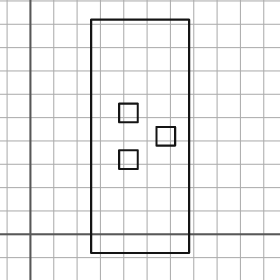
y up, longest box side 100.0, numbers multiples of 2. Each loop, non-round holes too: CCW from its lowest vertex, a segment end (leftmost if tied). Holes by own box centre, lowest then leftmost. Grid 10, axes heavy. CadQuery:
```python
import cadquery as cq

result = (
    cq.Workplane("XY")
    .moveTo(26.0, -8.0)
    .lineTo(68.0, -8.0)
    .lineTo(68.0, 92.0)
    .lineTo(26.0, 92.0)
    .close()
    .moveTo(38.0, 28.0)
    .lineTo(46.0, 28.0)
    .lineTo(46.0, 36.0)
    .lineTo(38.0, 36.0)
    .close()
    .moveTo(54.0, 38.0)
    .lineTo(62.0, 38.0)
    .lineTo(62.0, 46.0)
    .lineTo(54.0, 46.0)
    .close()
    .moveTo(38.0, 48.0)
    .lineTo(46.0, 48.0)
    .lineTo(46.0, 56.0)
    .lineTo(38.0, 56.0)
    .close()
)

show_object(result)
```